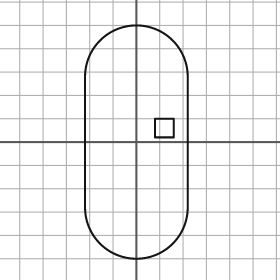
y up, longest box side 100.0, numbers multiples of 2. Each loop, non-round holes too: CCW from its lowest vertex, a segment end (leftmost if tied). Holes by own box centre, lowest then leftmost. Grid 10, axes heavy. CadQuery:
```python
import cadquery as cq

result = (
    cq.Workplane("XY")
    .moveTo(-22.0, -28.0)
    .threePointArc((0.0, -50.0), (22.0, -28.0))
    .lineTo(22.0, 28.0)
    .threePointArc((0.0, 50.0), (-22.0, 28.0))
    .close()
    .moveTo(8.0, 2.0)
    .lineTo(16.0, 2.0)
    .lineTo(16.0, 10.0)
    .lineTo(8.0, 10.0)
    .close()
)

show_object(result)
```